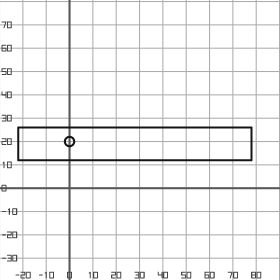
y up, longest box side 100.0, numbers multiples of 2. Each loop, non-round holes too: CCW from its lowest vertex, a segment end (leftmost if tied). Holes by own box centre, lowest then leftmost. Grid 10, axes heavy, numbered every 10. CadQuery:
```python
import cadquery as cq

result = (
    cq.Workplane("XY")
    .moveTo(-22.0, 12.0)
    .lineTo(78.0, 12.0)
    .lineTo(78.0, 26.0)
    .lineTo(-22.0, 26.0)
    .close()
    .moveTo(0.0, 20.0)
    .circle(2.0)
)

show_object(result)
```